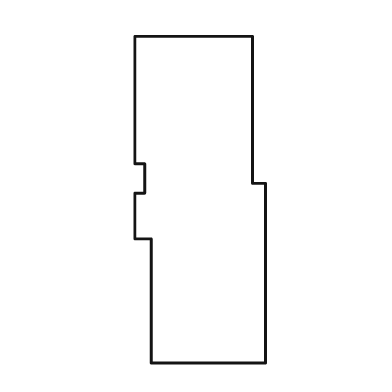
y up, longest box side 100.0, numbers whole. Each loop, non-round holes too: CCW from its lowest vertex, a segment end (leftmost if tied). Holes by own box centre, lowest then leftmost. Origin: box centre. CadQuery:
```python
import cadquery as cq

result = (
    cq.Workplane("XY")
    .moveTo(-15.0, -50.0)
    .lineTo(20.0, -50.0)
    .lineTo(20.0, 5.0)
    .lineTo(16.0, 5.0)
    .lineTo(16.0, 50.0)
    .lineTo(-20.0, 50.0)
    .lineTo(-20.0, 11.0)
    .lineTo(-17.0, 11.0)
    .lineTo(-17.0, 2.0)
    .lineTo(-20.0, 2.0)
    .lineTo(-20.0, -12.0)
    .lineTo(-15.0, -12.0)
    .close()
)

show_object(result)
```